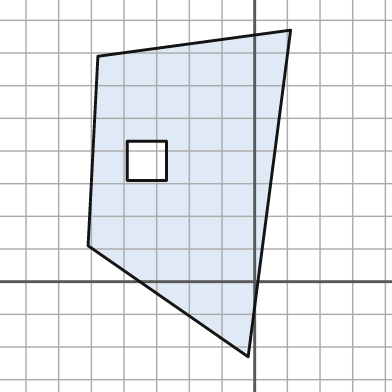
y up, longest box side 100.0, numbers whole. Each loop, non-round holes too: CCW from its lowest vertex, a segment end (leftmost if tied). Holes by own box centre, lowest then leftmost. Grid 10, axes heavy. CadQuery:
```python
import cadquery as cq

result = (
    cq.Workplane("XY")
    .moveTo(-2.0, -23.0)
    .lineTo(11.0, 77.0)
    .lineTo(-48.0, 69.0)
    .lineTo(-51.0, 11.0)
    .close()
    .moveTo(-39.0, 31.0)
    .lineTo(-27.0, 31.0)
    .lineTo(-27.0, 43.0)
    .lineTo(-39.0, 43.0)
    .close()
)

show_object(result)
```